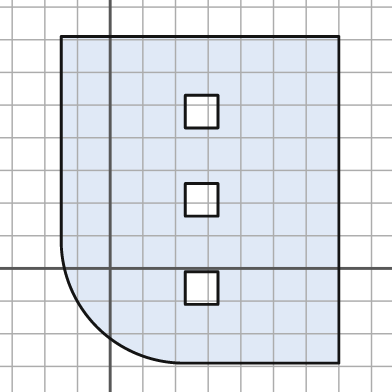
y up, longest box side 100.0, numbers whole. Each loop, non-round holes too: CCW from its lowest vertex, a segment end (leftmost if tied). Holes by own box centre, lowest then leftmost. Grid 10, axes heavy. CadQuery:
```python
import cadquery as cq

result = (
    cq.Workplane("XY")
    .moveTo(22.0, -29.0)
    .lineTo(70.0, -29.0)
    .lineTo(70.0, 71.0)
    .lineTo(-15.0, 71.0)
    .lineTo(-15.0, 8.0)
    .threePointArc((-4.0, -18.0), (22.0, -29.0))
    .close()
    .moveTo(23.0, -11.0)
    .lineTo(33.0, -11.0)
    .lineTo(33.0, -1.0)
    .lineTo(23.0, -1.0)
    .close()
    .moveTo(23.0, 16.0)
    .lineTo(33.0, 16.0)
    .lineTo(33.0, 26.0)
    .lineTo(23.0, 26.0)
    .close()
    .moveTo(23.0, 43.0)
    .lineTo(33.0, 43.0)
    .lineTo(33.0, 53.0)
    .lineTo(23.0, 53.0)
    .close()
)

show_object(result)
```